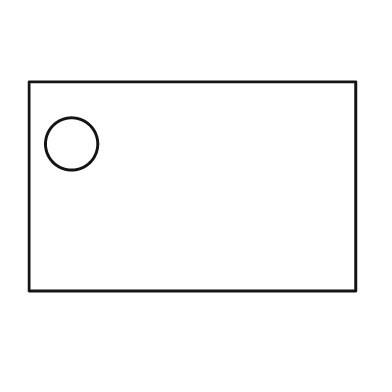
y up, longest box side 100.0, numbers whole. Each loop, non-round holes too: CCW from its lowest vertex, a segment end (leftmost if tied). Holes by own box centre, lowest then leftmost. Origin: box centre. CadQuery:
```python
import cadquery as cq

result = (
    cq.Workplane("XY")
    .moveTo(-50.0, -32.0)
    .lineTo(50.0, -32.0)
    .lineTo(50.0, 32.0)
    .lineTo(-50.0, 32.0)
    .close()
    .moveTo(-37.0, 13.0)
    .circle(8.0)
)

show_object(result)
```